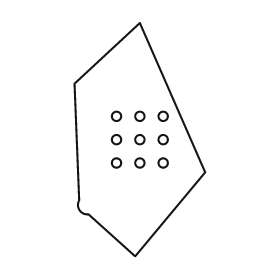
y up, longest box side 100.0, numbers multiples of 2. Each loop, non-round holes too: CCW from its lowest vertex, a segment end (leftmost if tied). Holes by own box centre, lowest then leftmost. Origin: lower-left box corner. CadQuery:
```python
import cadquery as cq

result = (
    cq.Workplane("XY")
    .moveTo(26.0, 0.0)
    .lineTo(56.0, 36.0)
    .lineTo(28.0, 100.0)
    .lineTo(0.0, 74.0)
    .lineTo(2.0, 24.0)
    .threePointArc((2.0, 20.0), (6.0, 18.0))
    .close()
    .moveTo(18.0, 40.0)
    .circle(2.0)
    .moveTo(28.0, 40.0)
    .circle(2.0)
    .moveTo(38.0, 40.0)
    .circle(2.0)
    .moveTo(18.0, 50.0)
    .circle(2.0)
    .moveTo(28.0, 50.0)
    .circle(2.0)
    .moveTo(38.0, 50.0)
    .circle(2.0)
    .moveTo(18.0, 60.0)
    .circle(2.0)
    .moveTo(28.0, 60.0)
    .circle(2.0)
    .moveTo(38.0, 60.0)
    .circle(2.0)
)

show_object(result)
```